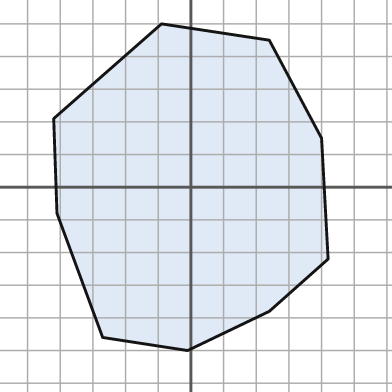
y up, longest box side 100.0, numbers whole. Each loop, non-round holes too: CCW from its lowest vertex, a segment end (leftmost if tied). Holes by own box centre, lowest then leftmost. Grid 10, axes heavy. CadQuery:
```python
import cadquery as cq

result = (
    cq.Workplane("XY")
    .moveTo(-1.0, -50.0)
    .lineTo(24.0, -38.0)
    .lineTo(42.0, -22.0)
    .lineTo(40.0, 15.0)
    .lineTo(24.0, 45.0)
    .lineTo(-9.0, 50.0)
    .lineTo(-42.0, 21.0)
    .lineTo(-41.0, -8.0)
    .lineTo(-27.0, -46.0)
    .close()
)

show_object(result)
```